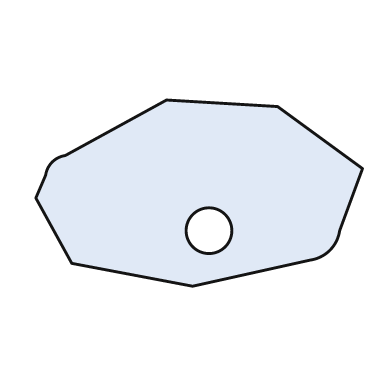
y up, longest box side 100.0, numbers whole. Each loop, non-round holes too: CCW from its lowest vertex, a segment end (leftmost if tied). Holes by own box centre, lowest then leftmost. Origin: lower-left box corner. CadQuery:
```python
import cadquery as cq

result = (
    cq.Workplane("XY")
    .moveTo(48.0, 0.0)
    .lineTo(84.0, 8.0)
    .threePointArc((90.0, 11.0), (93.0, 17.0))
    .lineTo(100.0, 36.0)
    .lineTo(74.0, 55.0)
    .lineTo(40.0, 57.0)
    .lineTo(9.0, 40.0)
    .threePointArc((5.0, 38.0), (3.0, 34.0))
    .lineTo(0.0, 27.0)
    .lineTo(11.0, 7.0)
    .close()
    .moveTo(53.0, 17.0)
    .circle(7.0)
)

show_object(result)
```